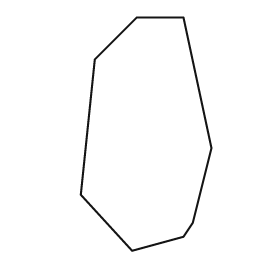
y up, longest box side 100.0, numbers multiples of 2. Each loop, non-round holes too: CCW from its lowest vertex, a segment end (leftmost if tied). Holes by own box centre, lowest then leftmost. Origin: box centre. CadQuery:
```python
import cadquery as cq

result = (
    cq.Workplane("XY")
    .moveTo(-6.0, -50.0)
    .lineTo(16.0, -44.0)
    .lineTo(20.0, -38.0)
    .lineTo(28.0, -6.0)
    .lineTo(16.0, 50.0)
    .lineTo(-4.0, 50.0)
    .lineTo(-22.0, 32.0)
    .lineTo(-28.0, -26.0)
    .close()
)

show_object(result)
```